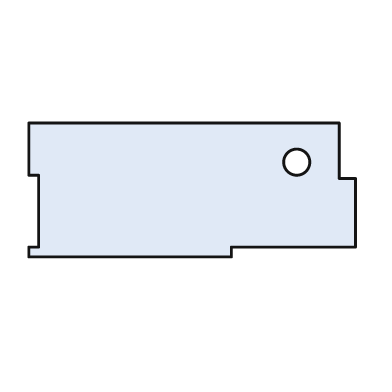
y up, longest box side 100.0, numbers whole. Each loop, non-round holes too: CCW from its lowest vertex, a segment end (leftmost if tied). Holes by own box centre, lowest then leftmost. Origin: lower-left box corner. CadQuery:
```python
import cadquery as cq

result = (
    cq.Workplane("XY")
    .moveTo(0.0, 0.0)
    .lineTo(62.0, 0.0)
    .lineTo(62.0, 3.0)
    .lineTo(100.0, 3.0)
    .lineTo(100.0, 24.0)
    .lineTo(95.0, 24.0)
    .lineTo(95.0, 41.0)
    .lineTo(0.0, 41.0)
    .lineTo(0.0, 25.0)
    .lineTo(3.0, 25.0)
    .lineTo(3.0, 3.0)
    .lineTo(0.0, 3.0)
    .close()
    .moveTo(82.0, 29.0)
    .circle(4.0)
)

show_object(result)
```